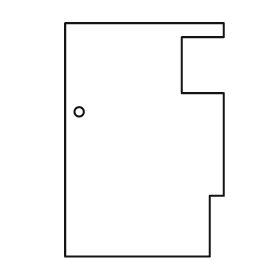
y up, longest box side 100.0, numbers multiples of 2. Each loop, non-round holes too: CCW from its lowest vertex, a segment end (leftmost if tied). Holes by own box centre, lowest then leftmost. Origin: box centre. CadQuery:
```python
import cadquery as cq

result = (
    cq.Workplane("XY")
    .moveTo(-34.0, -50.0)
    .lineTo(28.0, -50.0)
    .lineTo(28.0, -24.0)
    .lineTo(34.0, -24.0)
    .lineTo(34.0, 20.0)
    .lineTo(16.0, 20.0)
    .lineTo(16.0, 44.0)
    .lineTo(34.0, 44.0)
    .lineTo(34.0, 50.0)
    .lineTo(-34.0, 50.0)
    .close()
    .moveTo(-28.0, 12.0)
    .circle(2.0)
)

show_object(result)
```